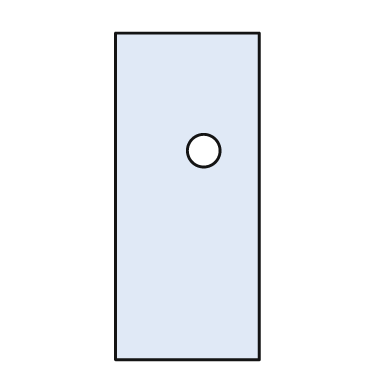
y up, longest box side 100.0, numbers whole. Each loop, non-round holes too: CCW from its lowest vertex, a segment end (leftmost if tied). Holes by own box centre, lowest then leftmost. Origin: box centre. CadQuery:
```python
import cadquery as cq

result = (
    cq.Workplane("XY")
    .moveTo(-22.0, -50.0)
    .lineTo(22.0, -50.0)
    .lineTo(22.0, 50.0)
    .lineTo(-22.0, 50.0)
    .close()
    .moveTo(5.0, 14.0)
    .circle(5.0)
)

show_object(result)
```